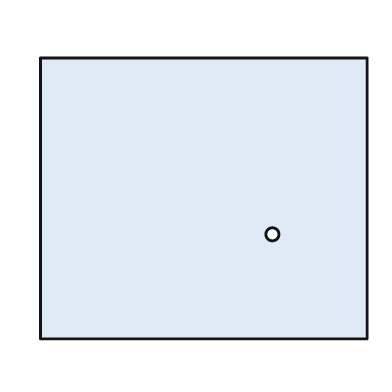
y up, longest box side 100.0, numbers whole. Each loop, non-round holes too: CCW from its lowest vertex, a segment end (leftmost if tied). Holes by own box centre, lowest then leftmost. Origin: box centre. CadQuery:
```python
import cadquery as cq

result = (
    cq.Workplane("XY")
    .moveTo(-50.0, -43.0)
    .lineTo(50.0, -43.0)
    .lineTo(50.0, 43.0)
    .lineTo(-50.0, 43.0)
    .close()
    .moveTo(21.0, -11.0)
    .circle(2.0)
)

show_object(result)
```